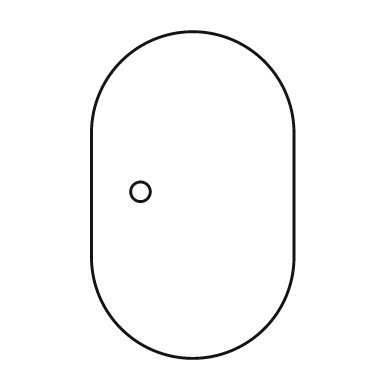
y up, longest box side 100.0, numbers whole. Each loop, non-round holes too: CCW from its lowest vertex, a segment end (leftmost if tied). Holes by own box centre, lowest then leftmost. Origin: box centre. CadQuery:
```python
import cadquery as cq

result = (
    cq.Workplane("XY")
    .moveTo(-31.0, -19.0)
    .threePointArc((0.0, -50.0), (31.0, -19.0))
    .lineTo(31.0, 19.0)
    .threePointArc((0.0, 50.0), (-31.0, 19.0))
    .close()
    .moveTo(-16.0, 1.0)
    .circle(3.0)
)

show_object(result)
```